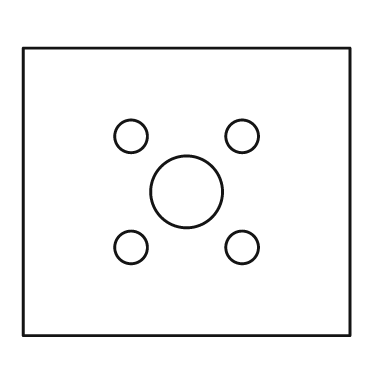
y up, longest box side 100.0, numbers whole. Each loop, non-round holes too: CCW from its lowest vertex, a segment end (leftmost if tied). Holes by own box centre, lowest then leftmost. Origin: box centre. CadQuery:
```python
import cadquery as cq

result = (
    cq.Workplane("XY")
    .moveTo(-50.0, -44.0)
    .lineTo(50.0, -44.0)
    .lineTo(50.0, 44.0)
    .lineTo(-50.0, 44.0)
    .close()
    .moveTo(-17.0, -17.0)
    .circle(5.0)
    .moveTo(17.0, -17.0)
    .circle(5.0)
    .moveTo(0.0, 0.0)
    .circle(11.0)
    .moveTo(-17.0, 17.0)
    .circle(5.0)
    .moveTo(17.0, 17.0)
    .circle(5.0)
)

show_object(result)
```